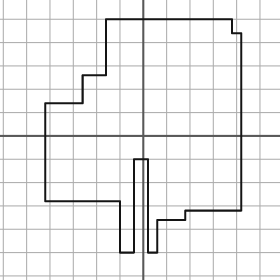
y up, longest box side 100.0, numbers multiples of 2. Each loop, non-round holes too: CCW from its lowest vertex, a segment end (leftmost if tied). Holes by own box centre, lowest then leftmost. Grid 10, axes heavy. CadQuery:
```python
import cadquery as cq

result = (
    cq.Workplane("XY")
    .moveTo(-10.0, -50.0)
    .lineTo(-4.0, -50.0)
    .lineTo(-4.0, -10.0)
    .lineTo(2.0, -10.0)
    .lineTo(2.0, -50.0)
    .lineTo(6.0, -50.0)
    .lineTo(6.0, -36.0)
    .lineTo(18.0, -36.0)
    .lineTo(18.0, -32.0)
    .lineTo(42.0, -32.0)
    .lineTo(42.0, 44.0)
    .lineTo(38.0, 44.0)
    .lineTo(38.0, 50.0)
    .lineTo(-16.0, 50.0)
    .lineTo(-16.0, 26.0)
    .lineTo(-26.0, 26.0)
    .lineTo(-26.0, 14.0)
    .lineTo(-42.0, 14.0)
    .lineTo(-42.0, -28.0)
    .lineTo(-10.0, -28.0)
    .close()
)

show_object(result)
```